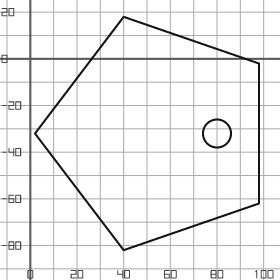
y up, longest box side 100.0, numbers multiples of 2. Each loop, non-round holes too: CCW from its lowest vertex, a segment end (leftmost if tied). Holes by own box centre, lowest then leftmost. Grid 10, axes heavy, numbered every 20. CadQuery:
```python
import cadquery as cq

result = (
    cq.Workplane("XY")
    .moveTo(40.0, -82.0)
    .lineTo(98.0, -62.0)
    .lineTo(98.0, -2.0)
    .lineTo(40.0, 18.0)
    .lineTo(2.0, -32.0)
    .close()
    .moveTo(80.0, -32.0)
    .circle(6.0)
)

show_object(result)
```